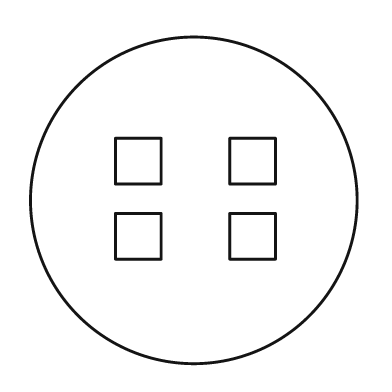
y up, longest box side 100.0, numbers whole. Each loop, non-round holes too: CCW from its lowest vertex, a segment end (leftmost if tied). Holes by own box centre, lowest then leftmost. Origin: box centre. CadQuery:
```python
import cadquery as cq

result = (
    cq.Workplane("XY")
    .moveTo(0.0, 0.0)
    .circle(50.0)
    .moveTo(-24.0, -18.0)
    .lineTo(-10.0, -18.0)
    .lineTo(-10.0, -4.0)
    .lineTo(-24.0, -4.0)
    .close()
    .moveTo(11.0, -18.0)
    .lineTo(25.0, -18.0)
    .lineTo(25.0, -4.0)
    .lineTo(11.0, -4.0)
    .close()
    .moveTo(-24.0, 5.0)
    .lineTo(-10.0, 5.0)
    .lineTo(-10.0, 19.0)
    .lineTo(-24.0, 19.0)
    .close()
    .moveTo(11.0, 5.0)
    .lineTo(25.0, 5.0)
    .lineTo(25.0, 19.0)
    .lineTo(11.0, 19.0)
    .close()
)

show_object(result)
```